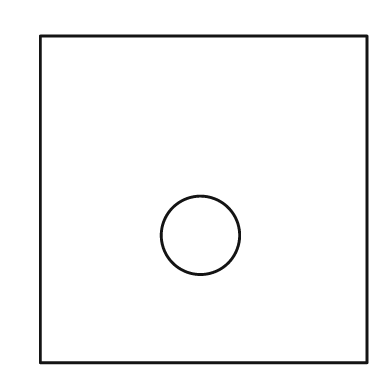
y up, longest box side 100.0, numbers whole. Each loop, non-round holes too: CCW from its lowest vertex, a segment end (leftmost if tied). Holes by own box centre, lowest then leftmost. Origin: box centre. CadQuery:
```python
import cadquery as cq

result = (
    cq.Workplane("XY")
    .moveTo(-50.0, -50.0)
    .lineTo(50.0, -50.0)
    .lineTo(50.0, 50.0)
    .lineTo(-50.0, 50.0)
    .close()
    .moveTo(-1.0, -11.0)
    .circle(12.0)
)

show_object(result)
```